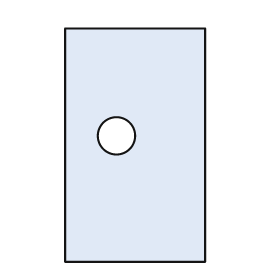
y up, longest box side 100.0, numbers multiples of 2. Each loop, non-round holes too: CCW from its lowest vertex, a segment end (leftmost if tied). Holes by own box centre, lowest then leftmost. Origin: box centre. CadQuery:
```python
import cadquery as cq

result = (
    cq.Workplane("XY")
    .moveTo(-30.0, -50.0)
    .lineTo(30.0, -50.0)
    .lineTo(30.0, 50.0)
    .lineTo(-30.0, 50.0)
    .close()
    .moveTo(-8.0, 4.0)
    .circle(8.0)
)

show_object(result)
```